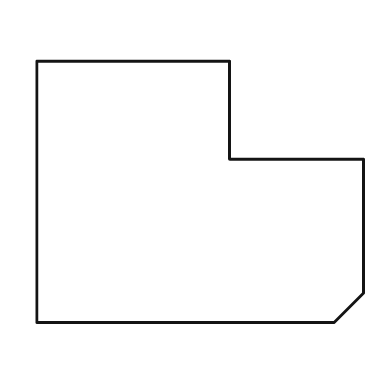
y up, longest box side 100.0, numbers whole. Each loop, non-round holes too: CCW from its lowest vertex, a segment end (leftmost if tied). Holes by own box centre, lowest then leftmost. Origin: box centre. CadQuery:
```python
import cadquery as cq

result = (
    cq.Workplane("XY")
    .moveTo(-50.0, -40.0)
    .lineTo(41.0, -40.0)
    .lineTo(50.0, -31.0)
    .lineTo(50.0, 10.0)
    .lineTo(9.0, 10.0)
    .lineTo(9.0, 40.0)
    .lineTo(-50.0, 40.0)
    .close()
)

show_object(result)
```